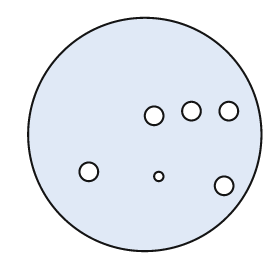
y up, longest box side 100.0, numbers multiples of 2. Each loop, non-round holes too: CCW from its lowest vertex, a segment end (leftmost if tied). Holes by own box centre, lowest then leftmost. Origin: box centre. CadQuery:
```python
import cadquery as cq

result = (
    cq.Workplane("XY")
    .moveTo(0.0, 0.0)
    .circle(50.0)
    .moveTo(34.0, -22.0)
    .circle(4.0)
    .moveTo(6.0, -18.0)
    .circle(2.0)
    .moveTo(-24.0, -16.0)
    .circle(4.0)
    .moveTo(4.0, 8.0)
    .circle(4.0)
    .moveTo(20.0, 10.0)
    .circle(4.0)
    .moveTo(36.0, 10.0)
    .circle(4.0)
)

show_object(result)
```